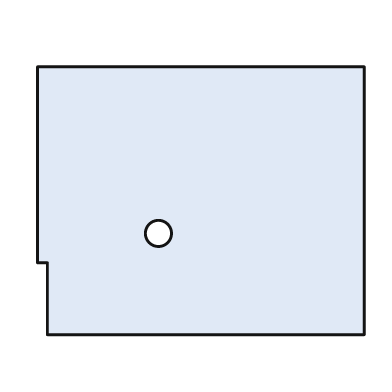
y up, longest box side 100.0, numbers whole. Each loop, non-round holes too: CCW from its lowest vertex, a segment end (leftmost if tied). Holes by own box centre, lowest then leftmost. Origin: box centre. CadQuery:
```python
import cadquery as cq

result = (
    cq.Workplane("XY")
    .moveTo(-47.0, -41.0)
    .lineTo(50.0, -41.0)
    .lineTo(50.0, 41.0)
    .lineTo(-50.0, 41.0)
    .lineTo(-50.0, -19.0)
    .lineTo(-47.0, -19.0)
    .close()
    .moveTo(-13.0, -10.0)
    .circle(4.0)
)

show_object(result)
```